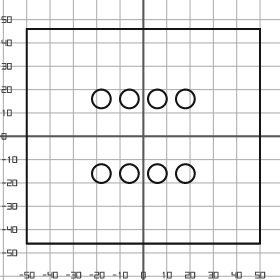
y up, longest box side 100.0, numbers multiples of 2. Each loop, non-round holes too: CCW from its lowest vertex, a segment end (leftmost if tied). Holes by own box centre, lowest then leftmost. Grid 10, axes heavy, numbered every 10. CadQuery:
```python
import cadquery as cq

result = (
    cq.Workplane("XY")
    .moveTo(-50.0, -46.0)
    .lineTo(50.0, -46.0)
    .lineTo(50.0, 46.0)
    .lineTo(-50.0, 46.0)
    .close()
    .moveTo(-18.0, -16.0)
    .circle(4.0)
    .moveTo(-6.0, -16.0)
    .circle(4.0)
    .moveTo(6.0, -16.0)
    .circle(4.0)
    .moveTo(18.0, -16.0)
    .circle(4.0)
    .moveTo(-18.0, 16.0)
    .circle(4.0)
    .moveTo(-6.0, 16.0)
    .circle(4.0)
    .moveTo(6.0, 16.0)
    .circle(4.0)
    .moveTo(18.0, 16.0)
    .circle(4.0)
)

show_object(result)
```